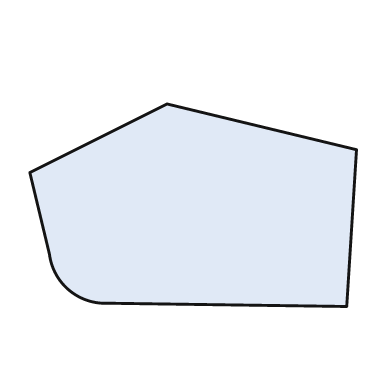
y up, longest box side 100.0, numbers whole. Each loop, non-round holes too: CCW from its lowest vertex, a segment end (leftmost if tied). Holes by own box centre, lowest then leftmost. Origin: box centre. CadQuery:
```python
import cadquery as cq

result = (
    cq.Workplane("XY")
    .moveTo(47.0, -31.0)
    .lineTo(50.0, 17.0)
    .lineTo(-8.0, 31.0)
    .lineTo(-50.0, 10.0)
    .lineTo(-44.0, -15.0)
    .threePointArc((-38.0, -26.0), (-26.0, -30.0))
    .close()
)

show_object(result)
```